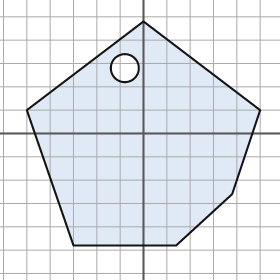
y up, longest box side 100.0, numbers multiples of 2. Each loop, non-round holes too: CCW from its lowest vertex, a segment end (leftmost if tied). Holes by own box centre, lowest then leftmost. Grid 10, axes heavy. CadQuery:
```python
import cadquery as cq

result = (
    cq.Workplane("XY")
    .moveTo(-30.0, -48.0)
    .lineTo(14.0, -48.0)
    .lineTo(38.0, -26.0)
    .lineTo(50.0, 10.0)
    .lineTo(0.0, 48.0)
    .lineTo(-50.0, 10.0)
    .close()
    .moveTo(-8.0, 28.0)
    .circle(6.0)
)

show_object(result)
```